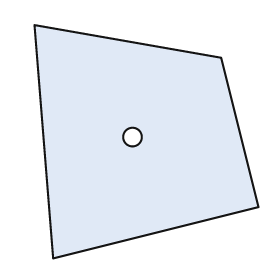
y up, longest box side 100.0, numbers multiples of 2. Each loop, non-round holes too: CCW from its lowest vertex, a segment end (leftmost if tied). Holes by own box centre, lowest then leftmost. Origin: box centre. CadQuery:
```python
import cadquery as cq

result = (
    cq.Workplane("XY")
    .moveTo(-40.0, -50.0)
    .lineTo(48.0, -28.0)
    .lineTo(32.0, 36.0)
    .lineTo(-48.0, 50.0)
    .close()
    .moveTo(-6.0, 2.0)
    .circle(4.0)
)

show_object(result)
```